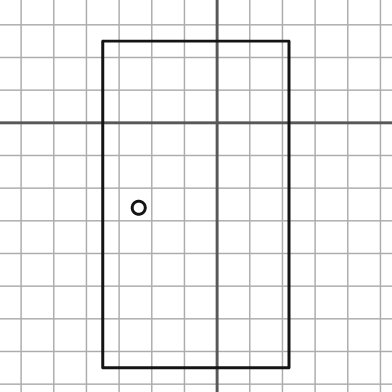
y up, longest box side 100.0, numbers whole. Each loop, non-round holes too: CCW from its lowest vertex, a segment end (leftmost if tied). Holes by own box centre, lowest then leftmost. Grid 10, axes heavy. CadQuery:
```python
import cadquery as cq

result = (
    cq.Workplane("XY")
    .moveTo(-35.0, -75.0)
    .lineTo(22.0, -75.0)
    .lineTo(22.0, 25.0)
    .lineTo(-35.0, 25.0)
    .close()
    .moveTo(-24.0, -26.0)
    .circle(2.0)
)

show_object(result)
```